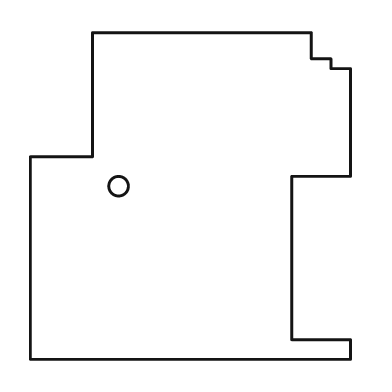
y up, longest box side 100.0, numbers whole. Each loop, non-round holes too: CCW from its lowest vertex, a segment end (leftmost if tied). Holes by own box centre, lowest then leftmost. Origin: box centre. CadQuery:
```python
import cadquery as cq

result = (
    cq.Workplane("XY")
    .moveTo(-49.0, -50.0)
    .lineTo(49.0, -50.0)
    .lineTo(49.0, -44.0)
    .lineTo(31.0, -44.0)
    .lineTo(31.0, 6.0)
    .lineTo(49.0, 6.0)
    .lineTo(49.0, 39.0)
    .lineTo(43.0, 39.0)
    .lineTo(43.0, 42.0)
    .lineTo(37.0, 42.0)
    .lineTo(37.0, 50.0)
    .lineTo(-30.0, 50.0)
    .lineTo(-30.0, 12.0)
    .lineTo(-49.0, 12.0)
    .close()
    .moveTo(-22.0, 3.0)
    .circle(3.0)
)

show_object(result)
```